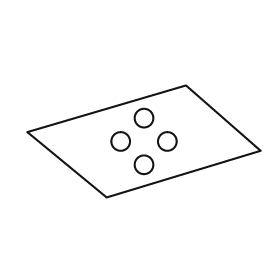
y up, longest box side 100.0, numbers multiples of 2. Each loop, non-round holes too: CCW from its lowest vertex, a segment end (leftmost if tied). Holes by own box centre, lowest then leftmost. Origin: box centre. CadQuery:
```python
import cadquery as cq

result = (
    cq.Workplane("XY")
    .moveTo(-16.0, -24.0)
    .lineTo(50.0, -4.0)
    .lineTo(18.0, 24.0)
    .lineTo(-50.0, 4.0)
    .close()
    .moveTo(0.0, -10.0)
    .circle(4.0)
    .moveTo(-10.0, 0.0)
    .circle(4.0)
    .moveTo(10.0, 0.0)
    .circle(4.0)
    .moveTo(0.0, 10.0)
    .circle(4.0)
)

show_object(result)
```